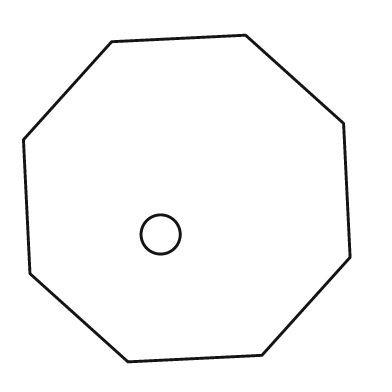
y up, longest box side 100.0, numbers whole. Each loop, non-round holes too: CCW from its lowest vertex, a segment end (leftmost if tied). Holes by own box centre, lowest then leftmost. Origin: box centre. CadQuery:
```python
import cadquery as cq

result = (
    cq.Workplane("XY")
    .moveTo(-18.0, -50.0)
    .lineTo(23.0, -48.0)
    .lineTo(50.0, -18.0)
    .lineTo(48.0, 23.0)
    .lineTo(18.0, 50.0)
    .lineTo(-23.0, 48.0)
    .lineTo(-50.0, 18.0)
    .lineTo(-48.0, -23.0)
    .close()
    .moveTo(-8.0, -11.0)
    .circle(6.0)
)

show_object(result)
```